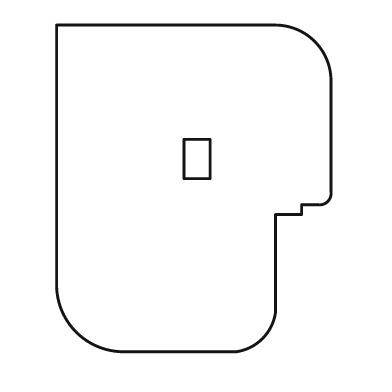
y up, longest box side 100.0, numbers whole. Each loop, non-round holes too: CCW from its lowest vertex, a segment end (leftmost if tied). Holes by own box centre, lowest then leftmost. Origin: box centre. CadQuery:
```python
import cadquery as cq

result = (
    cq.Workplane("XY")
    .moveTo(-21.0, -50.0)
    .lineTo(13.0, -50.0)
    .threePointArc((21.0, -46.0), (25.0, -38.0))
    .lineTo(25.0, -8.0)
    .lineTo(33.0, -8.0)
    .lineTo(33.0, -5.0)
    .lineTo(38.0, -5.0)
    .threePointArc((41.0, -4.0), (42.0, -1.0))
    .lineTo(42.0, 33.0)
    .threePointArc((37.0, 45.0), (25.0, 50.0))
    .lineTo(-42.0, 50.0)
    .lineTo(-42.0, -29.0)
    .threePointArc((-36.0, -44.0), (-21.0, -50.0))
    .close()
    .moveTo(-3.0, 3.0)
    .lineTo(5.0, 3.0)
    .lineTo(5.0, 15.0)
    .lineTo(-3.0, 15.0)
    .close()
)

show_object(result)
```